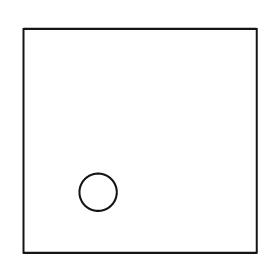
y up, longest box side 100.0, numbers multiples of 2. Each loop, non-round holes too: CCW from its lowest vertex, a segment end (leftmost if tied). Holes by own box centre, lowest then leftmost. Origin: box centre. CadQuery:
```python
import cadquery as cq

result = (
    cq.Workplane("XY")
    .moveTo(-50.0, -48.0)
    .lineTo(50.0, -48.0)
    .lineTo(50.0, 48.0)
    .lineTo(-50.0, 48.0)
    .close()
    .moveTo(-18.0, -22.0)
    .circle(8.0)
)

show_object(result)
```